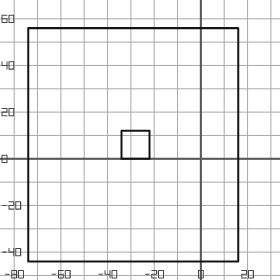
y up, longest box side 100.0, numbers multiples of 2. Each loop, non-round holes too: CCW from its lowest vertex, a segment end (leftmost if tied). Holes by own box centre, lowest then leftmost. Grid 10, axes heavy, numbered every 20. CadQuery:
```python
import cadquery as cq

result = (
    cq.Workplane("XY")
    .moveTo(-74.0, -44.0)
    .lineTo(16.0, -44.0)
    .lineTo(16.0, 56.0)
    .lineTo(-74.0, 56.0)
    .close()
    .moveTo(-34.0, 0.0)
    .lineTo(-22.0, 0.0)
    .lineTo(-22.0, 12.0)
    .lineTo(-34.0, 12.0)
    .close()
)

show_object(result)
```